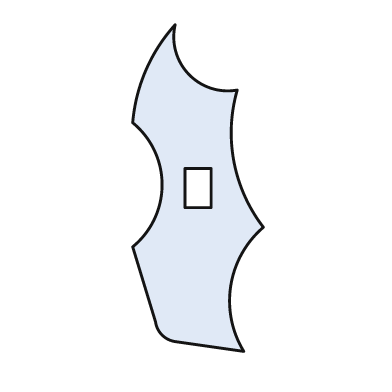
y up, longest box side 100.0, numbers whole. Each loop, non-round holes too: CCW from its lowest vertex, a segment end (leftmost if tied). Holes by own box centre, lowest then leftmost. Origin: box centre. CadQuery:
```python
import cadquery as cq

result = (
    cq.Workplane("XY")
    .moveTo(14.0, -50.0)
    .threePointArc((10.0, -30.0), (20.0, -12.0))
    .threePointArc((11.0, 8.0), (12.0, 30.0))
    .threePointArc((-3.0, 35.0), (-7.0, 50.0))
    .threePointArc((-16.0, 36.0), (-20.0, 20.0))
    .threePointArc((-11.0, 1.0), (-20.0, -18.0))
    .lineTo(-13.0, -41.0)
    .threePointArc((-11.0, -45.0), (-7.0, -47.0))
    .close()
    .moveTo(-4.0, -6.0)
    .lineTo(4.0, -6.0)
    .lineTo(4.0, 6.0)
    .lineTo(-4.0, 6.0)
    .close()
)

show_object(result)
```